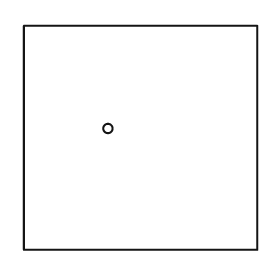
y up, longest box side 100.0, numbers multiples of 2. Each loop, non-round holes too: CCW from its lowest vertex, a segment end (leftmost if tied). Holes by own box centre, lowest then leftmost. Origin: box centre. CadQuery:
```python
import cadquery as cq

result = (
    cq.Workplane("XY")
    .moveTo(-50.0, -48.0)
    .lineTo(50.0, -48.0)
    .lineTo(50.0, 48.0)
    .lineTo(-50.0, 48.0)
    .close()
    .moveTo(-14.0, 4.0)
    .circle(2.0)
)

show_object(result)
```